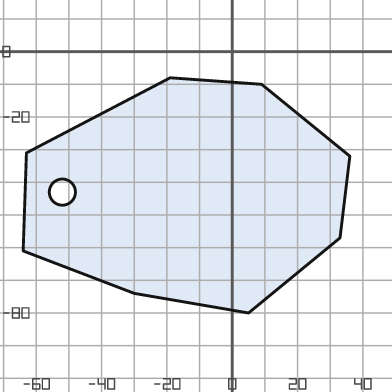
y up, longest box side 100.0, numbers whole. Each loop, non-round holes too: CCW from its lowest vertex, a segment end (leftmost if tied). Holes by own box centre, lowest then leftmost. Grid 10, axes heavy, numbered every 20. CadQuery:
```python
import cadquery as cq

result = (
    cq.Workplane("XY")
    .moveTo(5.0, -80.0)
    .lineTo(33.0, -57.0)
    .lineTo(36.0, -32.0)
    .lineTo(9.0, -10.0)
    .lineTo(-19.0, -8.0)
    .lineTo(-63.0, -31.0)
    .lineTo(-64.0, -61.0)
    .lineTo(-30.0, -74.0)
    .close()
    .moveTo(-52.0, -43.0)
    .circle(4.0)
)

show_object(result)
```